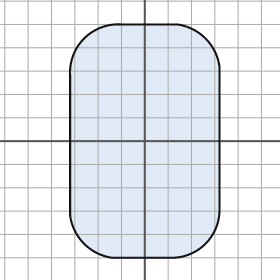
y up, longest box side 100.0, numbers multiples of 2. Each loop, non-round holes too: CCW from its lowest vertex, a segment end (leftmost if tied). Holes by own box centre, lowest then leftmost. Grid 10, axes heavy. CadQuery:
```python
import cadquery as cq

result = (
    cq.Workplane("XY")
    .moveTo(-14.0, -50.0)
    .lineTo(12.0, -50.0)
    .threePointArc((26.0, -44.0), (32.0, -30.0))
    .lineTo(32.0, 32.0)
    .threePointArc((26.0, 44.0), (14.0, 50.0))
    .lineTo(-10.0, 50.0)
    .threePointArc((-26.0, 44.0), (-32.0, 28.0))
    .lineTo(-32.0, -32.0)
    .threePointArc((-26.0, -44.0), (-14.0, -50.0))
    .close()
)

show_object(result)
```